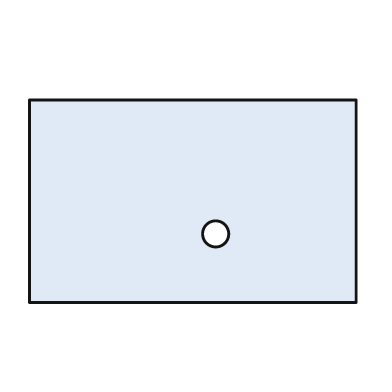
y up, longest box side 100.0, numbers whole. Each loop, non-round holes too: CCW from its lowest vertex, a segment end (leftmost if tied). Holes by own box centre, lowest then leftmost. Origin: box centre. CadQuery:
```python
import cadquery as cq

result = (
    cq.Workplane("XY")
    .moveTo(-50.0, -31.0)
    .lineTo(50.0, -31.0)
    .lineTo(50.0, 31.0)
    .lineTo(-50.0, 31.0)
    .close()
    .moveTo(7.0, -10.0)
    .circle(4.0)
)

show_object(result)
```